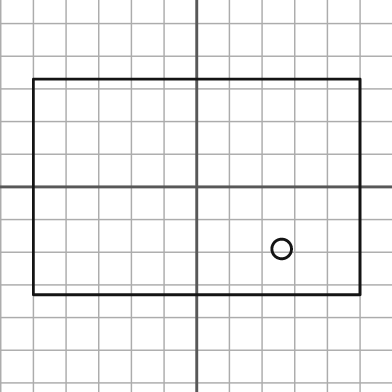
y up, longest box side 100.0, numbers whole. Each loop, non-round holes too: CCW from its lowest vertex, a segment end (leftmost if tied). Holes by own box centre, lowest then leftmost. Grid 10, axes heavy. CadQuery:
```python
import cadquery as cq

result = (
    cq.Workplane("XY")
    .moveTo(-50.0, -33.0)
    .lineTo(50.0, -33.0)
    .lineTo(50.0, 33.0)
    .lineTo(-50.0, 33.0)
    .close()
    .moveTo(26.0, -19.0)
    .circle(3.0)
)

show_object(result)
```